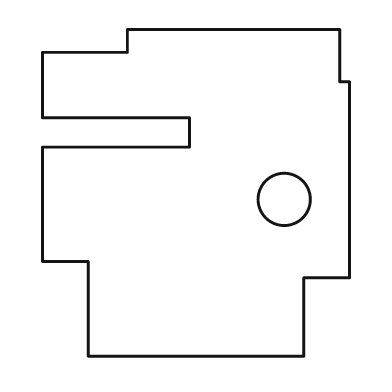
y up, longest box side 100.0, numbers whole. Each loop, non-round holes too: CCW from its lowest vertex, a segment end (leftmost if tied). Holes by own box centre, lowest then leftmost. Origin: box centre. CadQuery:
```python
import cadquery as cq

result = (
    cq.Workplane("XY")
    .moveTo(-33.0, -50.0)
    .lineTo(33.0, -50.0)
    .lineTo(33.0, -26.0)
    .lineTo(47.0, -26.0)
    .lineTo(47.0, 34.0)
    .lineTo(44.0, 34.0)
    .lineTo(44.0, 50.0)
    .lineTo(-21.0, 50.0)
    .lineTo(-21.0, 43.0)
    .lineTo(-47.0, 43.0)
    .lineTo(-47.0, 23.0)
    .lineTo(-2.0, 23.0)
    .lineTo(-2.0, 14.0)
    .lineTo(-47.0, 14.0)
    .lineTo(-47.0, -21.0)
    .lineTo(-33.0, -21.0)
    .close()
    .moveTo(27.0, -2.0)
    .circle(8.0)
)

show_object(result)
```